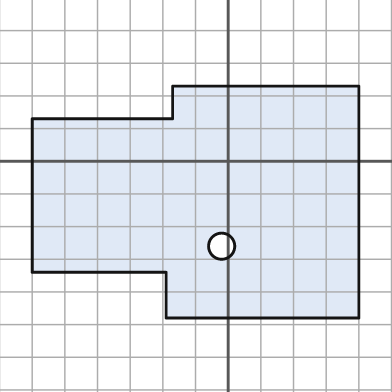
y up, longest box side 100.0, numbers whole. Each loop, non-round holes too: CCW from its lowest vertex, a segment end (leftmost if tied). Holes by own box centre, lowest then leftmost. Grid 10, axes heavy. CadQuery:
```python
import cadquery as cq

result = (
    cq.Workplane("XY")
    .moveTo(-19.0, -48.0)
    .lineTo(40.0, -48.0)
    .lineTo(40.0, 23.0)
    .lineTo(-17.0, 23.0)
    .lineTo(-17.0, 13.0)
    .lineTo(-60.0, 13.0)
    .lineTo(-60.0, -34.0)
    .lineTo(-19.0, -34.0)
    .close()
    .moveTo(-2.0, -26.0)
    .circle(4.0)
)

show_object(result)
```